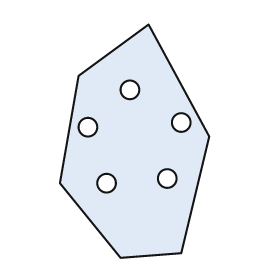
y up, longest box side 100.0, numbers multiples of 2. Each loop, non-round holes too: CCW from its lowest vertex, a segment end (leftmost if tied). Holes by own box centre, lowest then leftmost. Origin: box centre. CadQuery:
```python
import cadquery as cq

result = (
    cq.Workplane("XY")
    .moveTo(-6.0, -50.0)
    .lineTo(20.0, -48.0)
    .lineTo(32.0, 2.0)
    .lineTo(6.0, 50.0)
    .lineTo(-24.0, 28.0)
    .lineTo(-32.0, -18.0)
    .close()
    .moveTo(-12.0, -18.0)
    .circle(4.0)
    .moveTo(14.0, -16.0)
    .circle(4.0)
    .moveTo(-20.0, 6.0)
    .circle(4.0)
    .moveTo(20.0, 8.0)
    .circle(4.0)
    .moveTo(-2.0, 22.0)
    .circle(4.0)
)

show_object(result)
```